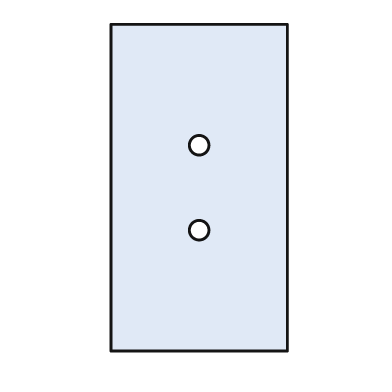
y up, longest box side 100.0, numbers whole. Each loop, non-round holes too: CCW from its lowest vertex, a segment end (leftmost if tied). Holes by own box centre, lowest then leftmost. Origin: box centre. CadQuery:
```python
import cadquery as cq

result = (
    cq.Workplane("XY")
    .moveTo(-27.0, -50.0)
    .lineTo(27.0, -50.0)
    .lineTo(27.0, 50.0)
    .lineTo(-27.0, 50.0)
    .close()
    .moveTo(0.0, -13.0)
    .circle(3.0)
    .moveTo(0.0, 13.0)
    .circle(3.0)
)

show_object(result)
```